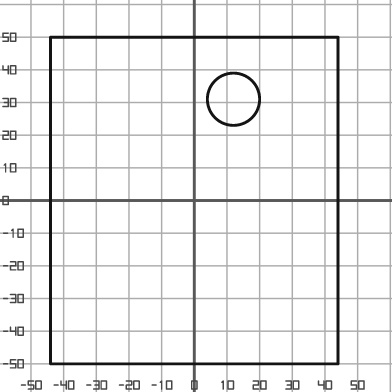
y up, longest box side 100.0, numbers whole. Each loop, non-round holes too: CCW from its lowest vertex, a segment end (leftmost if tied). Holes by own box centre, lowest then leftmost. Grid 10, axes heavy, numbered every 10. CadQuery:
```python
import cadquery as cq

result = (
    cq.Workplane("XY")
    .moveTo(-44.0, -50.0)
    .lineTo(44.0, -50.0)
    .lineTo(44.0, 50.0)
    .lineTo(-44.0, 50.0)
    .close()
    .moveTo(12.0, 31.0)
    .circle(8.0)
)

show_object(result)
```